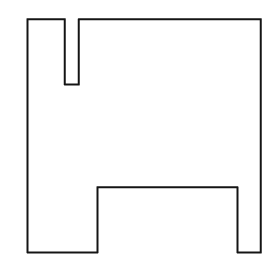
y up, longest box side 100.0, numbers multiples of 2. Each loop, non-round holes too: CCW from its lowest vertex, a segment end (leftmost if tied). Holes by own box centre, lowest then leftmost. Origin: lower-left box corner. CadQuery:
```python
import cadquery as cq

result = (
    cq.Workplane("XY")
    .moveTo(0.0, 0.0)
    .lineTo(30.0, 0.0)
    .lineTo(30.0, 28.0)
    .lineTo(90.0, 28.0)
    .lineTo(90.0, 0.0)
    .lineTo(100.0, 0.0)
    .lineTo(100.0, 100.0)
    .lineTo(22.0, 100.0)
    .lineTo(22.0, 72.0)
    .lineTo(16.0, 72.0)
    .lineTo(16.0, 100.0)
    .lineTo(0.0, 100.0)
    .close()
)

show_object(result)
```